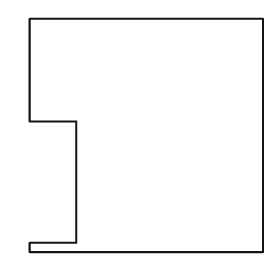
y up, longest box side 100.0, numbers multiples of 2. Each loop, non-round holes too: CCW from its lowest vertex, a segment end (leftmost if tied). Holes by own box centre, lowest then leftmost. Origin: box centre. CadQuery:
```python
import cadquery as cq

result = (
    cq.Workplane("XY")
    .moveTo(-50.0, -50.0)
    .lineTo(50.0, -50.0)
    .lineTo(50.0, 50.0)
    .lineTo(-50.0, 50.0)
    .lineTo(-50.0, 6.0)
    .lineTo(-30.0, 6.0)
    .lineTo(-30.0, -46.0)
    .lineTo(-50.0, -46.0)
    .close()
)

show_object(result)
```